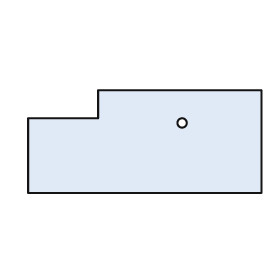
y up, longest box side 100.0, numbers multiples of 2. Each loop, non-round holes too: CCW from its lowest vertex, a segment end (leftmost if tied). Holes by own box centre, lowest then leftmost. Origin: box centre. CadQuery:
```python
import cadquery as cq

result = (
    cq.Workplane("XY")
    .moveTo(-50.0, -22.0)
    .lineTo(50.0, -22.0)
    .lineTo(50.0, 22.0)
    .lineTo(-20.0, 22.0)
    .lineTo(-20.0, 10.0)
    .lineTo(-50.0, 10.0)
    .close()
    .moveTo(16.0, 8.0)
    .circle(2.0)
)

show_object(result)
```